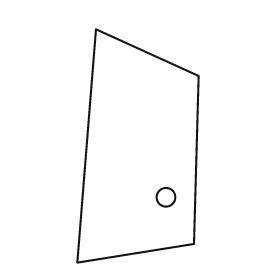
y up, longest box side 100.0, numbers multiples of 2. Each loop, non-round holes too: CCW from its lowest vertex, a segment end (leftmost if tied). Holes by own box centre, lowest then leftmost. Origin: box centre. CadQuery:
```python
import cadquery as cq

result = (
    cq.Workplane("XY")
    .moveTo(-26.0, -50.0)
    .lineTo(24.0, -42.0)
    .lineTo(26.0, 30.0)
    .lineTo(-18.0, 50.0)
    .close()
    .moveTo(12.0, -22.0)
    .circle(4.0)
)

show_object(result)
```